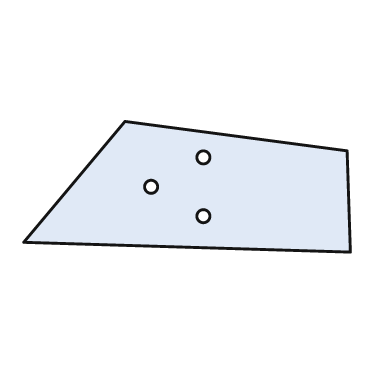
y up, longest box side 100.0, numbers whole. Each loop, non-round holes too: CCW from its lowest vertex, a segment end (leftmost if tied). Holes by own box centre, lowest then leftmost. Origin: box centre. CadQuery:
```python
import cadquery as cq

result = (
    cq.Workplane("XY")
    .moveTo(50.0, -20.0)
    .lineTo(49.0, 11.0)
    .lineTo(-19.0, 20.0)
    .lineTo(-50.0, -17.0)
    .close()
    .moveTo(5.0, -9.0)
    .circle(2.0)
    .moveTo(-11.0, 0.0)
    .circle(2.0)
    .moveTo(5.0, 9.0)
    .circle(2.0)
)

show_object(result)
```